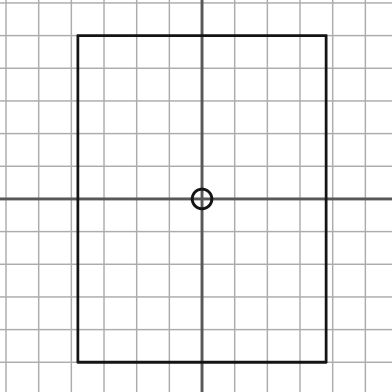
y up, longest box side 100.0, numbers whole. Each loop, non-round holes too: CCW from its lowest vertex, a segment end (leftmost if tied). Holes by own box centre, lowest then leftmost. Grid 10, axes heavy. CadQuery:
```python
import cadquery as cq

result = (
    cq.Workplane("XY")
    .moveTo(-38.0, -50.0)
    .lineTo(38.0, -50.0)
    .lineTo(38.0, 50.0)
    .lineTo(-38.0, 50.0)
    .close()
    .moveTo(0.0, 0.0)
    .circle(3.0)
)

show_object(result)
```